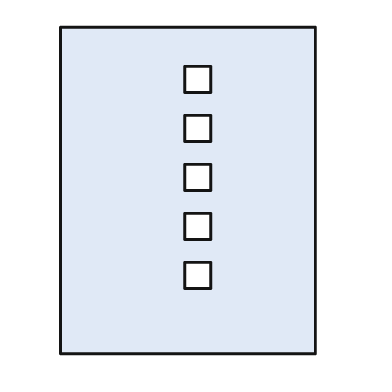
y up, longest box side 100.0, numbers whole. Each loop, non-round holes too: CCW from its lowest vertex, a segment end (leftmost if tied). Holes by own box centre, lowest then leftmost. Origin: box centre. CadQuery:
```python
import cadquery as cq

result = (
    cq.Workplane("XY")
    .moveTo(-39.0, -50.0)
    .lineTo(39.0, -50.0)
    .lineTo(39.0, 50.0)
    .lineTo(-39.0, 50.0)
    .close()
    .moveTo(-1.0, -30.0)
    .lineTo(7.0, -30.0)
    .lineTo(7.0, -22.0)
    .lineTo(-1.0, -22.0)
    .close()
    .moveTo(-1.0, -15.0)
    .lineTo(7.0, -15.0)
    .lineTo(7.0, -7.0)
    .lineTo(-1.0, -7.0)
    .close()
    .moveTo(-1.0, 0.0)
    .lineTo(7.0, 0.0)
    .lineTo(7.0, 8.0)
    .lineTo(-1.0, 8.0)
    .close()
    .moveTo(-1.0, 15.0)
    .lineTo(7.0, 15.0)
    .lineTo(7.0, 23.0)
    .lineTo(-1.0, 23.0)
    .close()
    .moveTo(-1.0, 30.0)
    .lineTo(7.0, 30.0)
    .lineTo(7.0, 38.0)
    .lineTo(-1.0, 38.0)
    .close()
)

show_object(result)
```